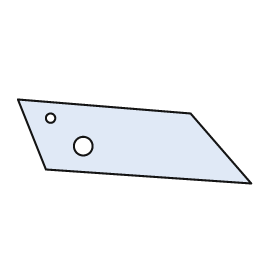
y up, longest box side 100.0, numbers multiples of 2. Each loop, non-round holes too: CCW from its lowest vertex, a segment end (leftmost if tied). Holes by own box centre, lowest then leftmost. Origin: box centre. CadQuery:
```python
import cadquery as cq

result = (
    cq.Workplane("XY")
    .moveTo(50.0, -18.0)
    .lineTo(24.0, 12.0)
    .lineTo(-50.0, 18.0)
    .lineTo(-38.0, -12.0)
    .close()
    .moveTo(-22.0, -2.0)
    .circle(4.0)
    .moveTo(-36.0, 10.0)
    .circle(2.0)
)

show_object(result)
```